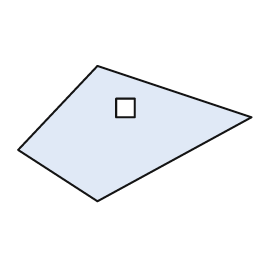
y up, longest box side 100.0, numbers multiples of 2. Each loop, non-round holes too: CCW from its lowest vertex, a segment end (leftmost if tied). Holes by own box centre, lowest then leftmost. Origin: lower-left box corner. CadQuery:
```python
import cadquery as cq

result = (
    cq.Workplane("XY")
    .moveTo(34.0, 0.0)
    .lineTo(100.0, 36.0)
    .lineTo(34.0, 58.0)
    .lineTo(0.0, 22.0)
    .close()
    .moveTo(42.0, 36.0)
    .lineTo(50.0, 36.0)
    .lineTo(50.0, 44.0)
    .lineTo(42.0, 44.0)
    .close()
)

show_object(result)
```